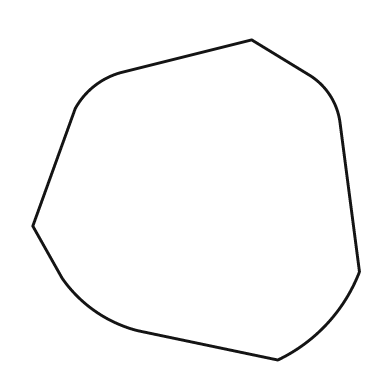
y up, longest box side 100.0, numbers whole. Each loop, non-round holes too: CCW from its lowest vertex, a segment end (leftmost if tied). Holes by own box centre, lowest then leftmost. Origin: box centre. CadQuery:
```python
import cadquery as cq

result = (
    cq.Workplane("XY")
    .moveTo(25.0, -49.0)
    .threePointArc((40.0, -38.0), (50.0, -22.0))
    .lineTo(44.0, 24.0)
    .threePointArc((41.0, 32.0), (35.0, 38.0))
    .lineTo(17.0, 49.0)
    .lineTo(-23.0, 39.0)
    .threePointArc((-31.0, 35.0), (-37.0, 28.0))
    .lineTo(-50.0, -8.0)
    .lineTo(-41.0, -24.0)
    .threePointArc((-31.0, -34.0), (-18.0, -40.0))
    .close()
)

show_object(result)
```